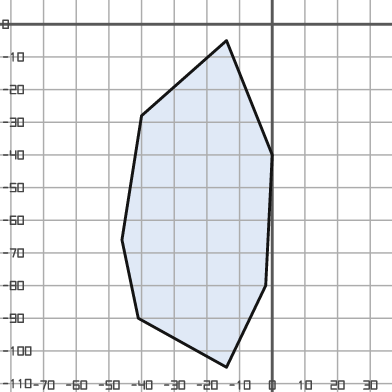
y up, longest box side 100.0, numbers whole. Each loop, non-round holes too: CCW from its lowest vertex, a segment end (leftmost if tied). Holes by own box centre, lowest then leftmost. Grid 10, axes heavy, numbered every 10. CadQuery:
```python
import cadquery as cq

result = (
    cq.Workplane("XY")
    .moveTo(-14.0, -105.0)
    .lineTo(-2.0, -80.0)
    .lineTo(0.0, -40.0)
    .lineTo(-14.0, -5.0)
    .lineTo(-40.0, -28.0)
    .lineTo(-46.0, -66.0)
    .lineTo(-41.0, -90.0)
    .close()
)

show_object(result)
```